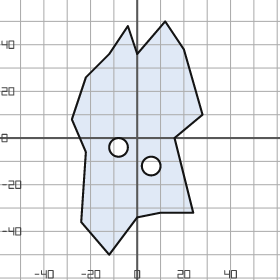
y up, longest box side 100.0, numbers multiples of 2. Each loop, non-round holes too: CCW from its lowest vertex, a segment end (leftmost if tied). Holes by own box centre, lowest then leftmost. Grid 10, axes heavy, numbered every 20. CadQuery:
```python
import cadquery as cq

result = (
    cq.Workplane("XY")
    .moveTo(-12.0, -50.0)
    .lineTo(0.0, -34.0)
    .lineTo(10.0, -32.0)
    .lineTo(24.0, -32.0)
    .lineTo(16.0, 0.0)
    .lineTo(28.0, 10.0)
    .lineTo(20.0, 38.0)
    .lineTo(12.0, 50.0)
    .lineTo(0.0, 36.0)
    .lineTo(-4.0, 48.0)
    .lineTo(-12.0, 36.0)
    .lineTo(-22.0, 26.0)
    .lineTo(-28.0, 8.0)
    .lineTo(-22.0, -6.0)
    .lineTo(-24.0, -36.0)
    .close()
    .moveTo(6.0, -12.0)
    .circle(4.0)
    .moveTo(-8.0, -4.0)
    .circle(4.0)
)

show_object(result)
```